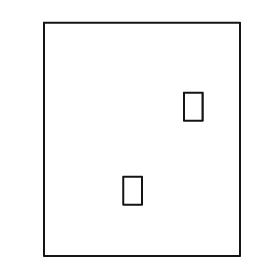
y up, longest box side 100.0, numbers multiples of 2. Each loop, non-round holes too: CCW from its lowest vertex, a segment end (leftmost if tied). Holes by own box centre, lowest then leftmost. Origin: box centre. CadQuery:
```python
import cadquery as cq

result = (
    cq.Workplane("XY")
    .moveTo(-42.0, -50.0)
    .lineTo(42.0, -50.0)
    .lineTo(42.0, 50.0)
    .lineTo(-42.0, 50.0)
    .close()
    .moveTo(-8.0, -28.0)
    .lineTo(0.0, -28.0)
    .lineTo(0.0, -16.0)
    .lineTo(-8.0, -16.0)
    .close()
    .moveTo(18.0, 8.0)
    .lineTo(26.0, 8.0)
    .lineTo(26.0, 20.0)
    .lineTo(18.0, 20.0)
    .close()
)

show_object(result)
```